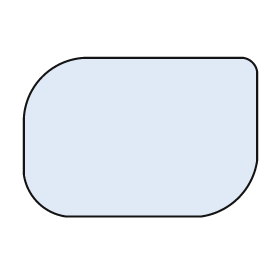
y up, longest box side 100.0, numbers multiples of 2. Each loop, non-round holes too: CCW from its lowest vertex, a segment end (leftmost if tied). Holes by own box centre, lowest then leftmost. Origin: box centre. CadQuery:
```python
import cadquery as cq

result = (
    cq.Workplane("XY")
    .moveTo(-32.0, -34.0)
    .lineTo(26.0, -34.0)
    .threePointArc((42.0, -26.0), (50.0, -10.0))
    .lineTo(50.0, 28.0)
    .threePointArc((48.0, 32.0), (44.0, 34.0))
    .lineTo(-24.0, 34.0)
    .threePointArc((-42.0, 26.0), (-50.0, 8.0))
    .lineTo(-50.0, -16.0)
    .threePointArc((-44.0, -28.0), (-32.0, -34.0))
    .close()
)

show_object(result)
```